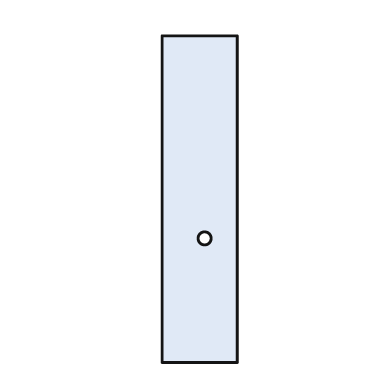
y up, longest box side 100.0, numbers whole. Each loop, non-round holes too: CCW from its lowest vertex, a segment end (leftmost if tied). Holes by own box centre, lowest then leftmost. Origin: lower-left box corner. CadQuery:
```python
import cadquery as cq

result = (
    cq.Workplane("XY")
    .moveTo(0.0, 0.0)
    .lineTo(23.0, 0.0)
    .lineTo(23.0, 100.0)
    .lineTo(0.0, 100.0)
    .close()
    .moveTo(13.0, 38.0)
    .circle(2.0)
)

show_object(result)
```